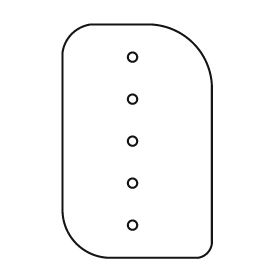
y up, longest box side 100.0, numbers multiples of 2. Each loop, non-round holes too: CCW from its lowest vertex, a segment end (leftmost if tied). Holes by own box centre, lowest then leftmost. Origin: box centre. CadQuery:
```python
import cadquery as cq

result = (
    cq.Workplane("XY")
    .moveTo(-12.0, -50.0)
    .lineTo(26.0, -50.0)
    .threePointArc((30.0, -48.0), (32.0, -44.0))
    .lineTo(32.0, 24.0)
    .threePointArc((24.0, 42.0), (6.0, 50.0))
    .lineTo(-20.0, 50.0)
    .threePointArc((-28.0, 46.0), (-32.0, 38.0))
    .lineTo(-32.0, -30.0)
    .threePointArc((-26.0, -44.0), (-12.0, -50.0))
    .close()
    .moveTo(-2.0, -36.0)
    .circle(2.0)
    .moveTo(-2.0, -18.0)
    .circle(2.0)
    .moveTo(-2.0, 0.0)
    .circle(2.0)
    .moveTo(-2.0, 18.0)
    .circle(2.0)
    .moveTo(-2.0, 36.0)
    .circle(2.0)
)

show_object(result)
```